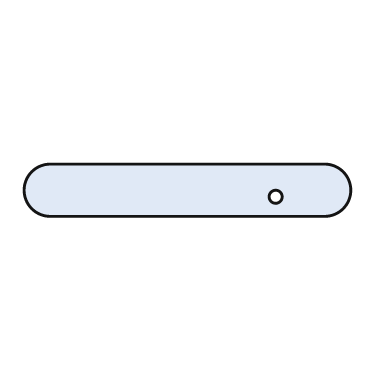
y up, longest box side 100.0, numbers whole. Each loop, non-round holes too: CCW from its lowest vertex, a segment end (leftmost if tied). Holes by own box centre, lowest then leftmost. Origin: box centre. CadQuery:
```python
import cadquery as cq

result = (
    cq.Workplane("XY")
    .moveTo(-42.0, -8.0)
    .lineTo(42.0, -8.0)
    .threePointArc((50.0, 0.0), (42.0, 8.0))
    .lineTo(-42.0, 8.0)
    .threePointArc((-50.0, 0.0), (-42.0, -8.0))
    .close()
    .moveTo(27.0, -2.0)
    .circle(2.0)
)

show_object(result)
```